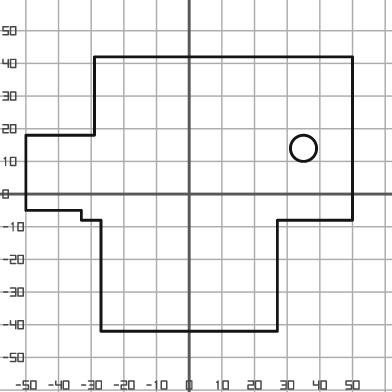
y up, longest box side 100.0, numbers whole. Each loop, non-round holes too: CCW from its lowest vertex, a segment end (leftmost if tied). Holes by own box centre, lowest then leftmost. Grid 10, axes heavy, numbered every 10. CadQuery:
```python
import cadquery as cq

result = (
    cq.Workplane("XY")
    .moveTo(-27.0, -42.0)
    .lineTo(27.0, -42.0)
    .lineTo(27.0, -8.0)
    .lineTo(50.0, -8.0)
    .lineTo(50.0, 42.0)
    .lineTo(-29.0, 42.0)
    .lineTo(-29.0, 18.0)
    .lineTo(-50.0, 18.0)
    .lineTo(-50.0, -5.0)
    .lineTo(-33.0, -5.0)
    .lineTo(-33.0, -8.0)
    .lineTo(-27.0, -8.0)
    .close()
    .moveTo(35.0, 14.0)
    .circle(4.0)
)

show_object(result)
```